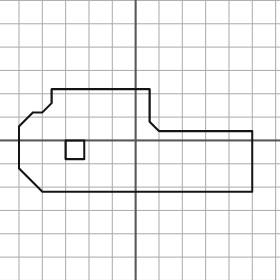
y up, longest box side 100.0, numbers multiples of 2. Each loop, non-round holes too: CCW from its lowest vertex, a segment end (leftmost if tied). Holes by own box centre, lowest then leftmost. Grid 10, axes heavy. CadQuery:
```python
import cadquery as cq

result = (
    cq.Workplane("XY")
    .moveTo(-40.0, -22.0)
    .lineTo(50.0, -22.0)
    .lineTo(50.0, 4.0)
    .lineTo(10.0, 4.0)
    .lineTo(6.0, 8.0)
    .lineTo(6.0, 22.0)
    .lineTo(-36.0, 22.0)
    .lineTo(-36.0, 16.0)
    .lineTo(-40.0, 12.0)
    .lineTo(-44.0, 12.0)
    .lineTo(-50.0, 6.0)
    .lineTo(-50.0, -12.0)
    .close()
    .moveTo(-30.0, -8.0)
    .lineTo(-22.0, -8.0)
    .lineTo(-22.0, 0.0)
    .lineTo(-30.0, 0.0)
    .close()
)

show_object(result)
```